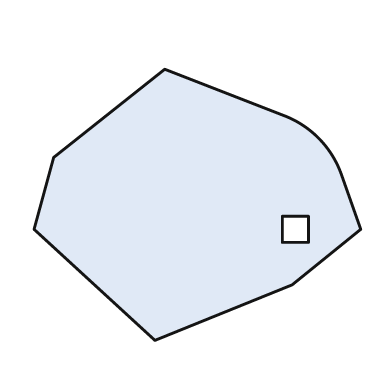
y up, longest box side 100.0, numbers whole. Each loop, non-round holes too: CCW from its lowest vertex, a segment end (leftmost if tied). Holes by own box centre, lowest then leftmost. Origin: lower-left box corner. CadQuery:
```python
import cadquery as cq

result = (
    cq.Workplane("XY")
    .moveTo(37.0, 0.0)
    .lineTo(79.0, 17.0)
    .lineTo(100.0, 34.0)
    .lineTo(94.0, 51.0)
    .threePointArc((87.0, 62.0), (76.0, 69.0))
    .lineTo(40.0, 83.0)
    .lineTo(6.0, 56.0)
    .lineTo(0.0, 34.0)
    .close()
    .moveTo(76.0, 30.0)
    .lineTo(84.0, 30.0)
    .lineTo(84.0, 38.0)
    .lineTo(76.0, 38.0)
    .close()
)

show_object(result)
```